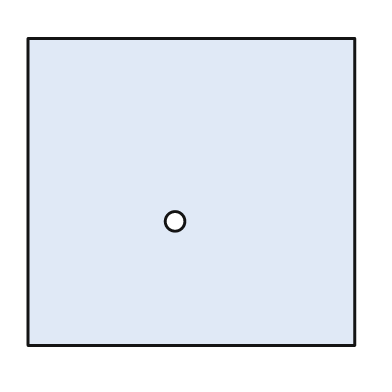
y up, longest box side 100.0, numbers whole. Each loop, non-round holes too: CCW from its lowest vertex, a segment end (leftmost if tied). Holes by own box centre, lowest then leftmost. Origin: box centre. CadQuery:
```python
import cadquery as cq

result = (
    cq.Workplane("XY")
    .moveTo(-50.0, -47.0)
    .lineTo(50.0, -47.0)
    .lineTo(50.0, 47.0)
    .lineTo(-50.0, 47.0)
    .close()
    .moveTo(-5.0, -9.0)
    .circle(3.0)
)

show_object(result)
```